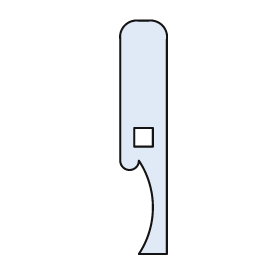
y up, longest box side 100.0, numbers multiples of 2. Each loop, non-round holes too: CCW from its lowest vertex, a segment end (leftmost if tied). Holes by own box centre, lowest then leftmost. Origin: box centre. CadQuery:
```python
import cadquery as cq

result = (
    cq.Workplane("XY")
    .moveTo(-2.0, -50.0)
    .lineTo(10.0, -50.0)
    .lineTo(10.0, 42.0)
    .threePointArc((8.0, 48.0), (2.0, 50.0))
    .lineTo(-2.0, 50.0)
    .threePointArc((-8.0, 48.0), (-10.0, 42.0))
    .lineTo(-10.0, -10.0)
    .threePointArc((-6.0, -14.0), (-2.0, -10.0))
    .threePointArc((4.0, -30.0), (-2.0, -50.0))
    .close()
    .moveTo(-4.0, -4.0)
    .lineTo(4.0, -4.0)
    .lineTo(4.0, 4.0)
    .lineTo(-4.0, 4.0)
    .close()
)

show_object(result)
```